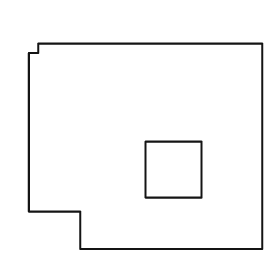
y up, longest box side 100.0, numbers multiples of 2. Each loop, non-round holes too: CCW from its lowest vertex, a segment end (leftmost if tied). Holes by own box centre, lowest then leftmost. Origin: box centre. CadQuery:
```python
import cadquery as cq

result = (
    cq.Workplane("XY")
    .moveTo(-28.0, -44.0)
    .lineTo(50.0, -44.0)
    .lineTo(50.0, 44.0)
    .lineTo(-46.0, 44.0)
    .lineTo(-46.0, 40.0)
    .lineTo(-50.0, 40.0)
    .lineTo(-50.0, -28.0)
    .lineTo(-28.0, -28.0)
    .close()
    .moveTo(0.0, -22.0)
    .lineTo(24.0, -22.0)
    .lineTo(24.0, 2.0)
    .lineTo(0.0, 2.0)
    .close()
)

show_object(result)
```